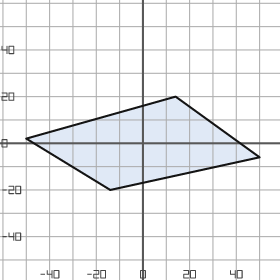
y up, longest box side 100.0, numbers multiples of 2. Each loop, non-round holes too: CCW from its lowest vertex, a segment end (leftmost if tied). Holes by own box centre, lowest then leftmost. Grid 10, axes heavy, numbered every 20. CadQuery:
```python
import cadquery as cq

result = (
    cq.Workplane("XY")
    .moveTo(-14.0, -20.0)
    .lineTo(50.0, -6.0)
    .lineTo(14.0, 20.0)
    .lineTo(-50.0, 2.0)
    .close()
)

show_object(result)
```